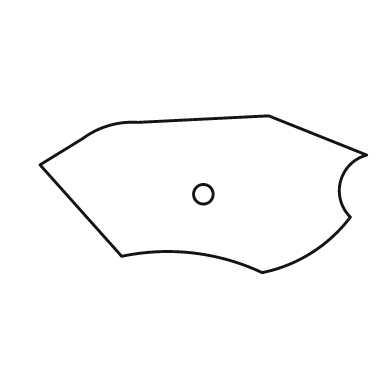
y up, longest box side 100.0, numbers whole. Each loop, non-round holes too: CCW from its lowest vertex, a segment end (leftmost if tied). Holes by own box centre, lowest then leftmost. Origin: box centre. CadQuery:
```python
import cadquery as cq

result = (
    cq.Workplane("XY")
    .moveTo(18.0, -24.0)
    .threePointArc((33.0, -18.0), (45.0, -7.0))
    .threePointArc((42.0, 4.0), (50.0, 12.0))
    .lineTo(20.0, 24.0)
    .lineTo(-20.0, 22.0)
    .threePointArc((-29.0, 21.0), (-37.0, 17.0))
    .lineTo(-50.0, 9.0)
    .lineTo(-25.0, -19.0)
    .threePointArc((-3.0, -18.0), (18.0, -24.0))
    .close()
    .moveTo(0.0, 0.0)
    .circle(3.0)
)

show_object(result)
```